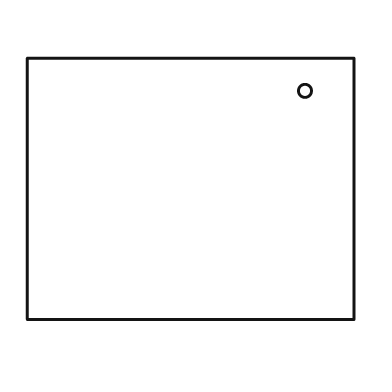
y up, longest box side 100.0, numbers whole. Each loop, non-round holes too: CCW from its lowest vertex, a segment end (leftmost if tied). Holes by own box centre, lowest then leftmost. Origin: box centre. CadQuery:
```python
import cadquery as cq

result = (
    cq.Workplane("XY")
    .moveTo(-50.0, -40.0)
    .lineTo(50.0, -40.0)
    .lineTo(50.0, 40.0)
    .lineTo(-50.0, 40.0)
    .close()
    .moveTo(35.0, 30.0)
    .circle(2.0)
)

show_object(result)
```